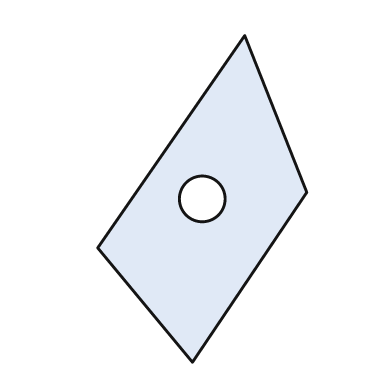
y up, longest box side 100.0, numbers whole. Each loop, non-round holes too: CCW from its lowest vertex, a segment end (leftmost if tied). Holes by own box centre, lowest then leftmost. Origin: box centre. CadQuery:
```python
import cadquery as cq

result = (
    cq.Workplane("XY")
    .moveTo(-3.0, -50.0)
    .lineTo(32.0, 2.0)
    .lineTo(13.0, 50.0)
    .lineTo(-32.0, -15.0)
    .close()
    .moveTo(0.0, 0.0)
    .circle(7.0)
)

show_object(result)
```